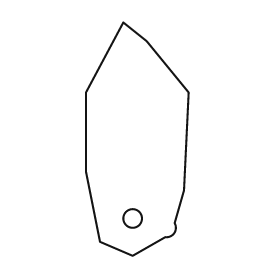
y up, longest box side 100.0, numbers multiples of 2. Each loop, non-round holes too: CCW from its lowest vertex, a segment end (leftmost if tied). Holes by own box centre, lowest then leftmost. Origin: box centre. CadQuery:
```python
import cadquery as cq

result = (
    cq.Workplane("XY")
    .moveTo(-2.0, -50.0)
    .lineTo(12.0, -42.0)
    .threePointArc((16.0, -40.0), (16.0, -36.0))
    .lineTo(20.0, -22.0)
    .lineTo(22.0, 20.0)
    .lineTo(4.0, 42.0)
    .lineTo(-6.0, 50.0)
    .lineTo(-22.0, 20.0)
    .lineTo(-22.0, -14.0)
    .lineTo(-16.0, -44.0)
    .close()
    .moveTo(-2.0, -34.0)
    .circle(4.0)
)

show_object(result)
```